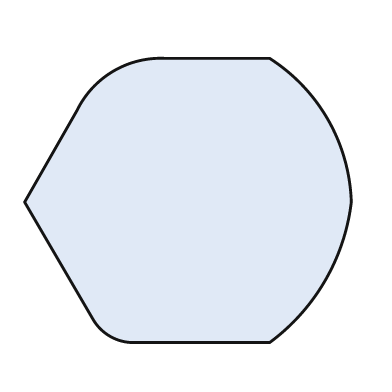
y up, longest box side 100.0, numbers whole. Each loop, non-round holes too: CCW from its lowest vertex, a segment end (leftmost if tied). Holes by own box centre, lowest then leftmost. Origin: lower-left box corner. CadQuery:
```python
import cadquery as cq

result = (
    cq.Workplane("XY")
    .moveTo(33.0, 0.0)
    .lineTo(75.0, 0.0)
    .threePointArc((92.0, 19.0), (100.0, 43.0))
    .threePointArc((93.0, 68.0), (75.0, 87.0))
    .lineTo(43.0, 87.0)
    .threePointArc((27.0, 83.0), (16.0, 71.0))
    .lineTo(0.0, 43.0)
    .lineTo(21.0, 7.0)
    .threePointArc((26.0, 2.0), (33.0, 0.0))
    .close()
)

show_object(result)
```